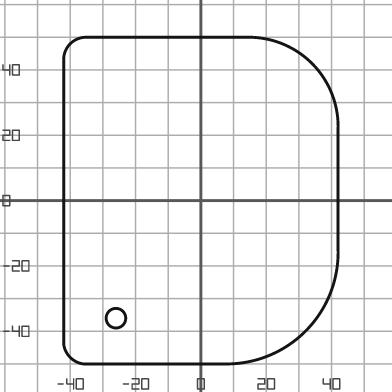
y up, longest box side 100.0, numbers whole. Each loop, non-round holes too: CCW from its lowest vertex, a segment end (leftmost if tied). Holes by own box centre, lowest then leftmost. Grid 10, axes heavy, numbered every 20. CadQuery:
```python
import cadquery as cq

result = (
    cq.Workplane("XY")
    .moveTo(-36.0, -50.0)
    .lineTo(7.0, -50.0)
    .threePointArc((32.0, -40.0), (42.0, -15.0))
    .lineTo(42.0, 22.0)
    .threePointArc((34.0, 42.0), (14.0, 50.0))
    .lineTo(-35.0, 50.0)
    .threePointArc((-40.0, 48.0), (-42.0, 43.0))
    .lineTo(-42.0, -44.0)
    .threePointArc((-40.0, -48.0), (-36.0, -50.0))
    .close()
    .moveTo(-26.0, -36.0)
    .circle(3.0)
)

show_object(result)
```